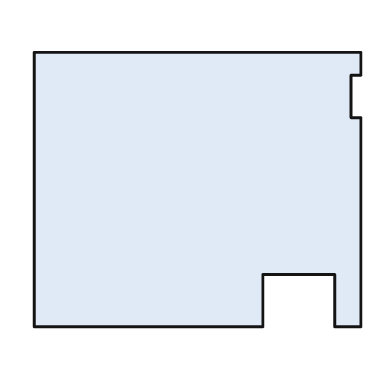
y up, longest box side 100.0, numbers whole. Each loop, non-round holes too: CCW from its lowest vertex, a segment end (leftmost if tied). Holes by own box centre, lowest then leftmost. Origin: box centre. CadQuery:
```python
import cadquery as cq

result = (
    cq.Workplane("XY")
    .moveTo(-50.0, -42.0)
    .lineTo(20.0, -42.0)
    .lineTo(20.0, -26.0)
    .lineTo(42.0, -26.0)
    .lineTo(42.0, -42.0)
    .lineTo(50.0, -42.0)
    .lineTo(50.0, 22.0)
    .lineTo(47.0, 22.0)
    .lineTo(47.0, 35.0)
    .lineTo(50.0, 35.0)
    .lineTo(50.0, 42.0)
    .lineTo(-50.0, 42.0)
    .close()
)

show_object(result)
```